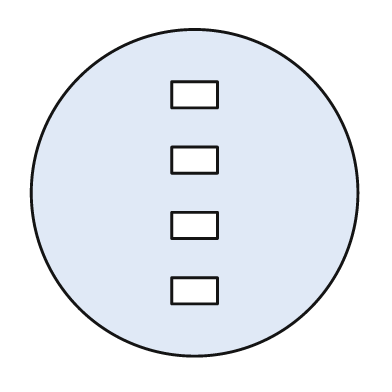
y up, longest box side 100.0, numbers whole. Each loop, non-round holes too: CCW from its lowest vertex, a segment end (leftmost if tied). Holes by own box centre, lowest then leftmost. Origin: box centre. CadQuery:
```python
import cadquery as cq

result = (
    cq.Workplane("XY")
    .moveTo(0.0, 0.0)
    .circle(50.0)
    .moveTo(-7.0, -34.0)
    .lineTo(7.0, -34.0)
    .lineTo(7.0, -26.0)
    .lineTo(-7.0, -26.0)
    .close()
    .moveTo(-7.0, -14.0)
    .lineTo(7.0, -14.0)
    .lineTo(7.0, -6.0)
    .lineTo(-7.0, -6.0)
    .close()
    .moveTo(-7.0, 6.0)
    .lineTo(7.0, 6.0)
    .lineTo(7.0, 14.0)
    .lineTo(-7.0, 14.0)
    .close()
    .moveTo(-7.0, 26.0)
    .lineTo(7.0, 26.0)
    .lineTo(7.0, 34.0)
    .lineTo(-7.0, 34.0)
    .close()
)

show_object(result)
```